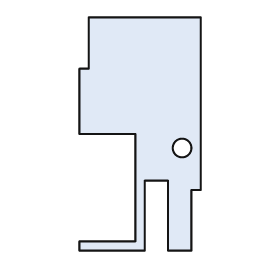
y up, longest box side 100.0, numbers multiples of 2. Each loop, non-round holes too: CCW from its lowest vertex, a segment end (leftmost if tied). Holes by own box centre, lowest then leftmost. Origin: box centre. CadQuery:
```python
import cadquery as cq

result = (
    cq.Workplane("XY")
    .moveTo(-26.0, -50.0)
    .lineTo(2.0, -50.0)
    .lineTo(2.0, -20.0)
    .lineTo(12.0, -20.0)
    .lineTo(12.0, -50.0)
    .lineTo(22.0, -50.0)
    .lineTo(22.0, -24.0)
    .lineTo(26.0, -24.0)
    .lineTo(26.0, 50.0)
    .lineTo(-22.0, 50.0)
    .lineTo(-22.0, 28.0)
    .lineTo(-26.0, 28.0)
    .lineTo(-26.0, 0.0)
    .lineTo(-2.0, 0.0)
    .lineTo(-2.0, -46.0)
    .lineTo(-26.0, -46.0)
    .close()
    .moveTo(18.0, -6.0)
    .circle(4.0)
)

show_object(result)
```